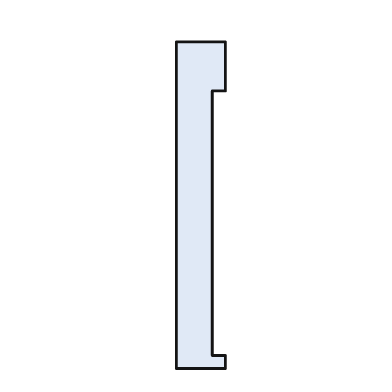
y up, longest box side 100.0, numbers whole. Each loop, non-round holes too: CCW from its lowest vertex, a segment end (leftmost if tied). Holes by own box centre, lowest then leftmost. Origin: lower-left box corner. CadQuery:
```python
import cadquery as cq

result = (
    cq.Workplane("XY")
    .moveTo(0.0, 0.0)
    .lineTo(15.0, 0.0)
    .lineTo(15.0, 4.0)
    .lineTo(11.0, 4.0)
    .lineTo(11.0, 85.0)
    .lineTo(15.0, 85.0)
    .lineTo(15.0, 100.0)
    .lineTo(0.0, 100.0)
    .close()
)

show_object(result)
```